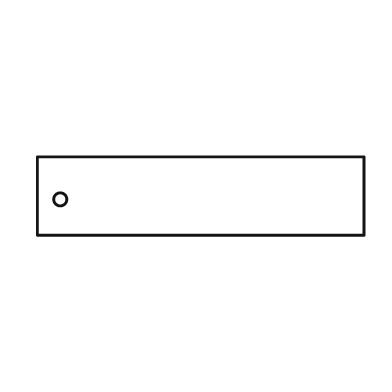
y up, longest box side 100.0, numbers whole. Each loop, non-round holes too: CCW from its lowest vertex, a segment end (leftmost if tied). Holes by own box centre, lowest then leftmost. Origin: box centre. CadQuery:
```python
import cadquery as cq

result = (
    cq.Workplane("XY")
    .moveTo(-50.0, -12.0)
    .lineTo(50.0, -12.0)
    .lineTo(50.0, 12.0)
    .lineTo(-50.0, 12.0)
    .close()
    .moveTo(-43.0, -1.0)
    .circle(2.0)
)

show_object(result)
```